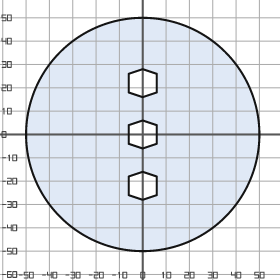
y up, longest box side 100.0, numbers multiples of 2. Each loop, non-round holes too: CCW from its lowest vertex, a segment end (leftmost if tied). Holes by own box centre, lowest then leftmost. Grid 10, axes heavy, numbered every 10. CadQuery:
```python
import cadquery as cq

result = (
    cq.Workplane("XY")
    .moveTo(0.0, 0.0)
    .circle(50.0)
    .moveTo(0.0, -28.0)
    .lineTo(6.0, -26.0)
    .lineTo(6.0, -18.0)
    .lineTo(0.0, -16.0)
    .lineTo(-6.0, -18.0)
    .lineTo(-6.0, -26.0)
    .close()
    .moveTo(0.0, -6.0)
    .lineTo(6.0, -4.0)
    .lineTo(6.0, 4.0)
    .lineTo(0.0, 6.0)
    .lineTo(-6.0, 4.0)
    .lineTo(-6.0, -4.0)
    .close()
    .moveTo(0.0, 16.0)
    .lineTo(6.0, 18.0)
    .lineTo(6.0, 26.0)
    .lineTo(0.0, 28.0)
    .lineTo(-6.0, 26.0)
    .lineTo(-6.0, 18.0)
    .close()
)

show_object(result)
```